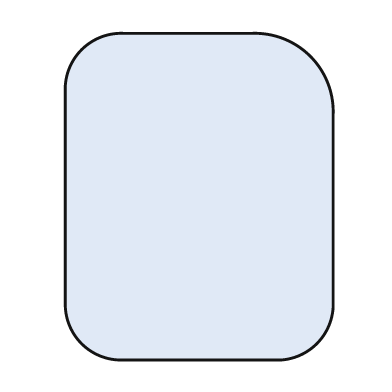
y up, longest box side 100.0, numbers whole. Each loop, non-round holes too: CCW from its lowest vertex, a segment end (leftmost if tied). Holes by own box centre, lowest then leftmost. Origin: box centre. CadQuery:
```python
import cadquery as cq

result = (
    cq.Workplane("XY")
    .moveTo(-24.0, -50.0)
    .lineTo(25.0, -50.0)
    .threePointArc((36.0, -45.0), (41.0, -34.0))
    .lineTo(41.0, 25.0)
    .threePointArc((34.0, 43.0), (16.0, 50.0))
    .lineTo(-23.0, 50.0)
    .threePointArc((-36.0, 45.0), (-41.0, 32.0))
    .lineTo(-41.0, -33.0)
    .threePointArc((-36.0, -45.0), (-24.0, -50.0))
    .close()
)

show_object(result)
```